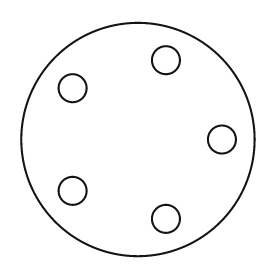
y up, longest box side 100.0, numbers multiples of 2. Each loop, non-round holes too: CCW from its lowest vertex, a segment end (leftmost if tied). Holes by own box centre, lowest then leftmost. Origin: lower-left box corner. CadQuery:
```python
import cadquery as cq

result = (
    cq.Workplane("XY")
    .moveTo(50.0, 50.0)
    .circle(50.0)
    .moveTo(62.0, 16.0)
    .circle(6.0)
    .moveTo(22.0, 28.0)
    .circle(6.0)
    .moveTo(86.0, 50.0)
    .circle(6.0)
    .moveTo(22.0, 72.0)
    .circle(6.0)
    .moveTo(62.0, 84.0)
    .circle(6.0)
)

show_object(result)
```